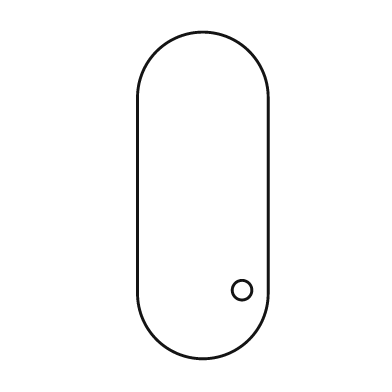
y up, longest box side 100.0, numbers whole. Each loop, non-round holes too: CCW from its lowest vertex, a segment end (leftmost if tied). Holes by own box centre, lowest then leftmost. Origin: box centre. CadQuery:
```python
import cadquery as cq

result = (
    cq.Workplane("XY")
    .moveTo(-20.0, -30.0)
    .threePointArc((0.0, -50.0), (20.0, -30.0))
    .lineTo(20.0, 30.0)
    .threePointArc((0.0, 50.0), (-20.0, 30.0))
    .close()
    .moveTo(12.0, -29.0)
    .circle(3.0)
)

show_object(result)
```